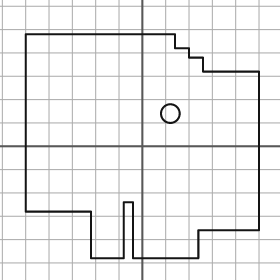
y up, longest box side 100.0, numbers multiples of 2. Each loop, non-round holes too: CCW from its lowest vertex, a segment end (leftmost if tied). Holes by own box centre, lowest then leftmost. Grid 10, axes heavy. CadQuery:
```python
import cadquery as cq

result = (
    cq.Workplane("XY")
    .moveTo(-22.0, -48.0)
    .lineTo(-8.0, -48.0)
    .lineTo(-8.0, -24.0)
    .lineTo(-4.0, -24.0)
    .lineTo(-4.0, -48.0)
    .lineTo(24.0, -48.0)
    .lineTo(24.0, -36.0)
    .lineTo(50.0, -36.0)
    .lineTo(50.0, 32.0)
    .lineTo(26.0, 32.0)
    .lineTo(26.0, 38.0)
    .lineTo(20.0, 38.0)
    .lineTo(20.0, 42.0)
    .lineTo(14.0, 42.0)
    .lineTo(14.0, 48.0)
    .lineTo(-50.0, 48.0)
    .lineTo(-50.0, -28.0)
    .lineTo(-22.0, -28.0)
    .close()
    .moveTo(12.0, 14.0)
    .circle(4.0)
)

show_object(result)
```